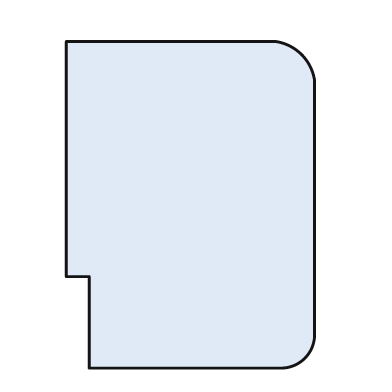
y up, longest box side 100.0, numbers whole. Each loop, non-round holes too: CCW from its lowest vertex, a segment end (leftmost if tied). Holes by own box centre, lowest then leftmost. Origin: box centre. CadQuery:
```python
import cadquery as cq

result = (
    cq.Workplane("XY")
    .moveTo(-31.0, -50.0)
    .lineTo(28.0, -50.0)
    .threePointArc((35.0, -47.0), (38.0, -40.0))
    .lineTo(38.0, 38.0)
    .threePointArc((34.0, 46.0), (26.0, 50.0))
    .lineTo(-38.0, 50.0)
    .lineTo(-38.0, -22.0)
    .lineTo(-31.0, -22.0)
    .close()
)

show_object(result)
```